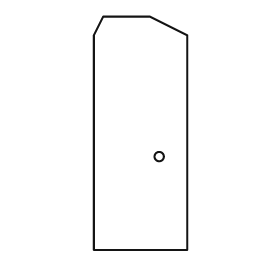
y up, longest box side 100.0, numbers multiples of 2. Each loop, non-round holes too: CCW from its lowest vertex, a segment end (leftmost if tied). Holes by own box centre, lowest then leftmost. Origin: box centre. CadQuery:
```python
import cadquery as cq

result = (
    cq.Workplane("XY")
    .moveTo(-20.0, -50.0)
    .lineTo(20.0, -50.0)
    .lineTo(20.0, 42.0)
    .lineTo(4.0, 50.0)
    .lineTo(-16.0, 50.0)
    .lineTo(-20.0, 42.0)
    .close()
    .moveTo(8.0, -10.0)
    .circle(2.0)
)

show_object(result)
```